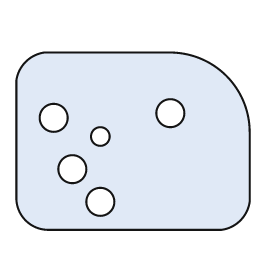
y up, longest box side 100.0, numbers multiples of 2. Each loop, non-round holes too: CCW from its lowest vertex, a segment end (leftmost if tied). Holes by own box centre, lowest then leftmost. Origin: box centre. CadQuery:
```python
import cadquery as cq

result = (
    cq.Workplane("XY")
    .moveTo(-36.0, -38.0)
    .lineTo(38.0, -38.0)
    .threePointArc((46.0, -34.0), (50.0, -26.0))
    .lineTo(50.0, 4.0)
    .threePointArc((40.0, 28.0), (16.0, 38.0))
    .lineTo(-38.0, 38.0)
    .threePointArc((-46.0, 34.0), (-50.0, 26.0))
    .lineTo(-50.0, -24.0)
    .threePointArc((-46.0, -34.0), (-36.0, -38.0))
    .close()
    .moveTo(-14.0, -26.0)
    .circle(6.0)
    .moveTo(-26.0, -12.0)
    .circle(6.0)
    .moveTo(-14.0, 2.0)
    .circle(4.0)
    .moveTo(-34.0, 10.0)
    .circle(6.0)
    .moveTo(16.0, 12.0)
    .circle(6.0)
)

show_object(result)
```